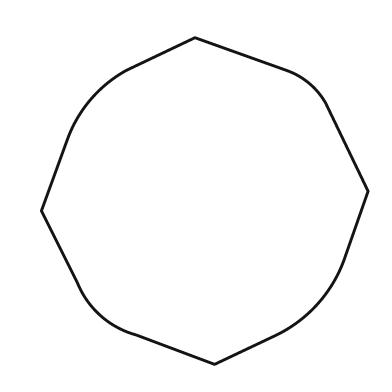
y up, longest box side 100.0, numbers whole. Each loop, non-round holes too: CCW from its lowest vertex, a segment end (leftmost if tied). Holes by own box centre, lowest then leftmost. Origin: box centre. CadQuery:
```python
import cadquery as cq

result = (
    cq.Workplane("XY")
    .moveTo(3.0, -50.0)
    .lineTo(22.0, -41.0)
    .threePointArc((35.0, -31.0), (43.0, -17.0))
    .lineTo(50.0, 3.0)
    .lineTo(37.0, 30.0)
    .threePointArc((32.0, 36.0), (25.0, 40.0))
    .lineTo(-3.0, 50.0)
    .lineTo(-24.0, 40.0)
    .threePointArc((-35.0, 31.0), (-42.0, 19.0))
    .lineTo(-50.0, -3.0)
    .lineTo(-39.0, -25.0)
    .threePointArc((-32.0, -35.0), (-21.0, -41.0))
    .close()
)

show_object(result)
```